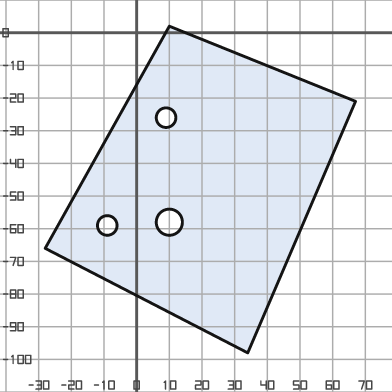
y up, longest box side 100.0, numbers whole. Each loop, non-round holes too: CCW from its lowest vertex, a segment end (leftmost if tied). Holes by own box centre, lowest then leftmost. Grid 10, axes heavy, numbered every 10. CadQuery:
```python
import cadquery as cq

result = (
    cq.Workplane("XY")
    .moveTo(34.0, -98.0)
    .lineTo(67.0, -21.0)
    .lineTo(10.0, 2.0)
    .lineTo(-28.0, -66.0)
    .close()
    .moveTo(-9.0, -59.0)
    .circle(3.0)
    .moveTo(10.0, -58.0)
    .circle(4.0)
    .moveTo(9.0, -26.0)
    .circle(3.0)
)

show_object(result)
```